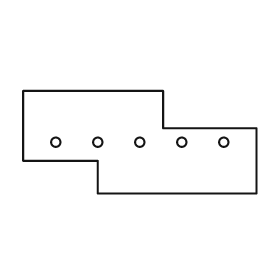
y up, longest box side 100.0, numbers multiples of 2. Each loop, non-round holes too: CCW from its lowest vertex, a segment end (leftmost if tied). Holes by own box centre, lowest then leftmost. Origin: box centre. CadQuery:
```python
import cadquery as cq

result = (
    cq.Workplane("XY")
    .moveTo(-18.0, -22.0)
    .lineTo(50.0, -22.0)
    .lineTo(50.0, 6.0)
    .lineTo(10.0, 6.0)
    .lineTo(10.0, 22.0)
    .lineTo(-50.0, 22.0)
    .lineTo(-50.0, -8.0)
    .lineTo(-18.0, -8.0)
    .close()
    .moveTo(-36.0, 0.0)
    .circle(2.0)
    .moveTo(-18.0, 0.0)
    .circle(2.0)
    .moveTo(0.0, 0.0)
    .circle(2.0)
    .moveTo(18.0, 0.0)
    .circle(2.0)
    .moveTo(36.0, 0.0)
    .circle(2.0)
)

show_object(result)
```